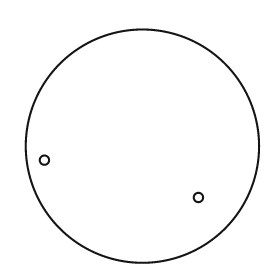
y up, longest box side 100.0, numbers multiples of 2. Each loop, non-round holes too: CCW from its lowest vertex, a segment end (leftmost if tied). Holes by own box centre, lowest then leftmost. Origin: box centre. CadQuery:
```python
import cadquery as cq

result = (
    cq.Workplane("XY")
    .moveTo(0.0, 0.0)
    .circle(50.0)
    .moveTo(24.0, -22.0)
    .circle(2.0)
    .moveTo(-42.0, -6.0)
    .circle(2.0)
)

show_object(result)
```